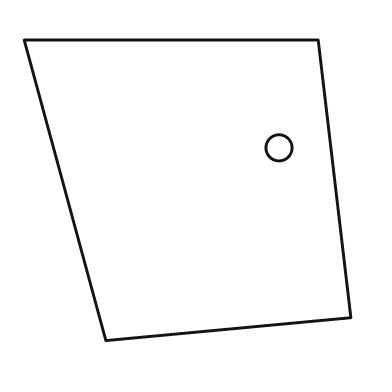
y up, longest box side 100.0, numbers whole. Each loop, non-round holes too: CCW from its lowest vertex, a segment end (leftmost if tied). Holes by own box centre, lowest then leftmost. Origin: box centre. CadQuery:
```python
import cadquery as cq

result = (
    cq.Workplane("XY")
    .moveTo(-25.0, -46.0)
    .lineTo(50.0, -39.0)
    .lineTo(40.0, 46.0)
    .lineTo(-50.0, 46.0)
    .close()
    .moveTo(28.0, 13.0)
    .circle(4.0)
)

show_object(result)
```